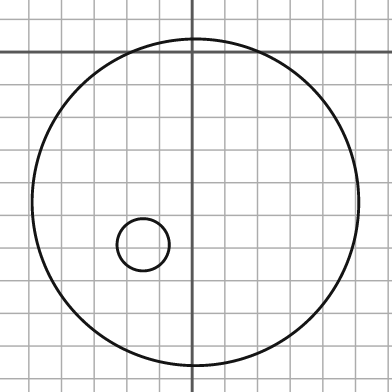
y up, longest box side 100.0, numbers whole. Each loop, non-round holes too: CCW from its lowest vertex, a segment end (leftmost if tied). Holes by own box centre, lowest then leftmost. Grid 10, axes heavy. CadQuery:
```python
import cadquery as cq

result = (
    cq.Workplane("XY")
    .moveTo(1.0, -46.0)
    .circle(50.0)
    .moveTo(-15.0, -59.0)
    .circle(8.0)
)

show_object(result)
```